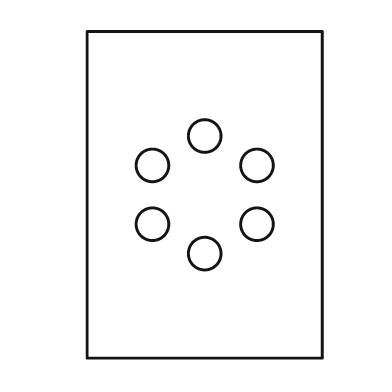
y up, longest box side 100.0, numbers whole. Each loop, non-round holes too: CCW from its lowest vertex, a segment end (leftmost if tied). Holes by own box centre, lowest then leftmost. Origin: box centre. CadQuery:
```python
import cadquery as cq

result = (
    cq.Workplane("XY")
    .moveTo(-36.0, -50.0)
    .lineTo(36.0, -50.0)
    .lineTo(36.0, 50.0)
    .lineTo(-36.0, 50.0)
    .close()
    .moveTo(0.0, -18.0)
    .circle(5.0)
    .moveTo(-16.0, -9.0)
    .circle(5.0)
    .moveTo(16.0, -9.0)
    .circle(5.0)
    .moveTo(-16.0, 9.0)
    .circle(5.0)
    .moveTo(16.0, 9.0)
    .circle(5.0)
    .moveTo(0.0, 18.0)
    .circle(5.0)
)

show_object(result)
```